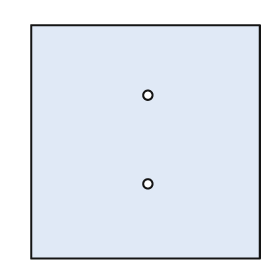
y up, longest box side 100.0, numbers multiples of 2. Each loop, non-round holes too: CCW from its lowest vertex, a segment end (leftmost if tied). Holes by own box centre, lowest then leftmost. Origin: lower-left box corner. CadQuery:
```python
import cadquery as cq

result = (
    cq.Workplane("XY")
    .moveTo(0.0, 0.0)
    .lineTo(98.0, 0.0)
    .lineTo(98.0, 100.0)
    .lineTo(0.0, 100.0)
    .close()
    .moveTo(50.0, 32.0)
    .circle(2.0)
    .moveTo(50.0, 70.0)
    .circle(2.0)
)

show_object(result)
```